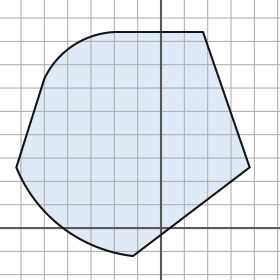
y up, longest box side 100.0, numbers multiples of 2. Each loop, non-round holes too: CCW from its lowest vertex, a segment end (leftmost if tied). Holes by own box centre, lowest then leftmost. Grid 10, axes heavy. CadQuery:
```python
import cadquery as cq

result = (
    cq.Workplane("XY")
    .moveTo(-12.0, -12.0)
    .lineTo(38.0, 26.0)
    .lineTo(18.0, 84.0)
    .lineTo(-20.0, 84.0)
    .threePointArc((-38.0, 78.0), (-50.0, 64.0))
    .lineTo(-62.0, 26.0)
    .threePointArc((-42.0, 0.0), (-12.0, -12.0))
    .close()
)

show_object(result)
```